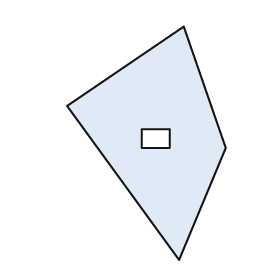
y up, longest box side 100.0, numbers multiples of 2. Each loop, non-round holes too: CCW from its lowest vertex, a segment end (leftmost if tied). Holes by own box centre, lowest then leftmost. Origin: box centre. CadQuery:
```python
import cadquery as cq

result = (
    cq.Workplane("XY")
    .moveTo(14.0, -50.0)
    .lineTo(34.0, -2.0)
    .lineTo(16.0, 50.0)
    .lineTo(-34.0, 16.0)
    .close()
    .moveTo(-2.0, -2.0)
    .lineTo(10.0, -2.0)
    .lineTo(10.0, 6.0)
    .lineTo(-2.0, 6.0)
    .close()
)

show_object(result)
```